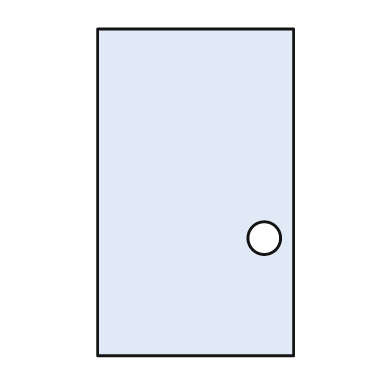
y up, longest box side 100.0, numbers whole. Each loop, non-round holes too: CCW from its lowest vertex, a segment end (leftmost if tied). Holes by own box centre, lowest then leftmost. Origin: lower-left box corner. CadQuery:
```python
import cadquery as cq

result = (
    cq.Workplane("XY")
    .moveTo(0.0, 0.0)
    .lineTo(60.0, 0.0)
    .lineTo(60.0, 100.0)
    .lineTo(0.0, 100.0)
    .close()
    .moveTo(51.0, 36.0)
    .circle(5.0)
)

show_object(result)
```